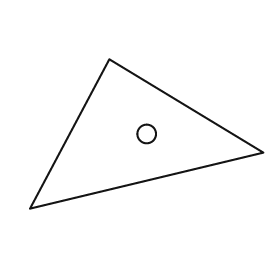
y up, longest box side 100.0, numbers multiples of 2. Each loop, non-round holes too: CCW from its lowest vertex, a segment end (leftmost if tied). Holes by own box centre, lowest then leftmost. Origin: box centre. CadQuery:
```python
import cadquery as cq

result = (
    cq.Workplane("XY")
    .moveTo(-50.0, -32.0)
    .lineTo(50.0, -8.0)
    .lineTo(-16.0, 32.0)
    .close()
    .moveTo(0.0, 0.0)
    .circle(4.0)
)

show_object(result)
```